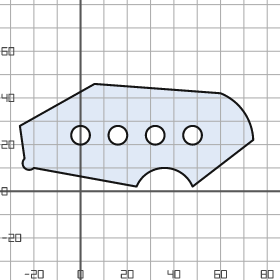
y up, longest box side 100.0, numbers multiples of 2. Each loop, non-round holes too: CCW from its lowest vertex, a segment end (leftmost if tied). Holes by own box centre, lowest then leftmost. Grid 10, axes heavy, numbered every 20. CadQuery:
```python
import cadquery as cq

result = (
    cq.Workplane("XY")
    .moveTo(24.0, 2.0)
    .threePointArc((36.0, 10.0), (48.0, 2.0))
    .lineTo(74.0, 22.0)
    .threePointArc((70.0, 34.0), (60.0, 42.0))
    .lineTo(6.0, 46.0)
    .lineTo(-26.0, 28.0)
    .lineTo(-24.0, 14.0)
    .threePointArc((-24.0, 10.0), (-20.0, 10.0))
    .close()
    .moveTo(0.0, 24.0)
    .circle(4.0)
    .moveTo(16.0, 24.0)
    .circle(4.0)
    .moveTo(32.0, 24.0)
    .circle(4.0)
    .moveTo(48.0, 24.0)
    .circle(4.0)
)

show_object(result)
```